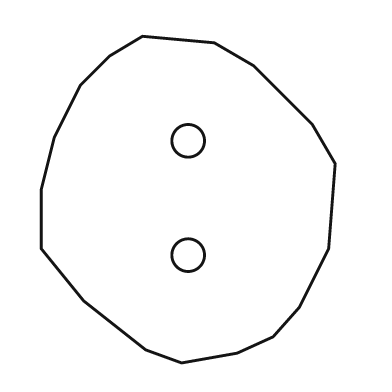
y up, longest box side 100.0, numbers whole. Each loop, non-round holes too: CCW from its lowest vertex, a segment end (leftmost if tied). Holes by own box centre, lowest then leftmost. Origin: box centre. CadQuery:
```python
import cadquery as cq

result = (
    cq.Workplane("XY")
    .moveTo(-2.0, -50.0)
    .lineTo(15.0, -47.0)
    .lineTo(26.0, -42.0)
    .lineTo(34.0, -33.0)
    .lineTo(43.0, -15.0)
    .lineTo(45.0, 11.0)
    .lineTo(38.0, 23.0)
    .lineTo(20.0, 41.0)
    .lineTo(8.0, 48.0)
    .lineTo(-14.0, 50.0)
    .lineTo(-24.0, 44.0)
    .lineTo(-33.0, 35.0)
    .lineTo(-41.0, 19.0)
    .lineTo(-45.0, 3.0)
    .lineTo(-45.0, -15.0)
    .lineTo(-32.0, -31.0)
    .lineTo(-13.0, -46.0)
    .close()
    .moveTo(0.0, -17.0)
    .circle(5.0)
    .moveTo(0.0, 18.0)
    .circle(5.0)
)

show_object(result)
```